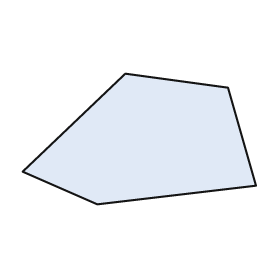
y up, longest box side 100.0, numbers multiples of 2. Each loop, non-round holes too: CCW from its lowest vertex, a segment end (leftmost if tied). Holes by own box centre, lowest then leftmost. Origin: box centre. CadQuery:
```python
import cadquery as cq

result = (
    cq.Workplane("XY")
    .moveTo(-18.0, -28.0)
    .lineTo(50.0, -20.0)
    .lineTo(38.0, 22.0)
    .lineTo(-6.0, 28.0)
    .lineTo(-50.0, -14.0)
    .close()
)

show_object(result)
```